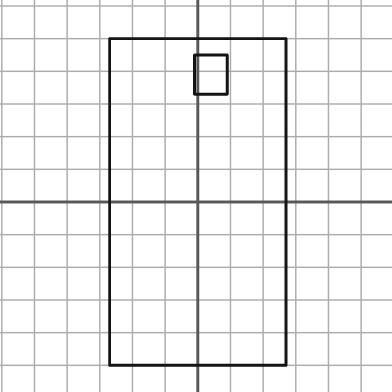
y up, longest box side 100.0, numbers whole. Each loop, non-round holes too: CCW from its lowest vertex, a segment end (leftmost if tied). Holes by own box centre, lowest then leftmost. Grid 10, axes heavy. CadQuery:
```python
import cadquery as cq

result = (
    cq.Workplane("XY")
    .moveTo(-27.0, -50.0)
    .lineTo(27.0, -50.0)
    .lineTo(27.0, 50.0)
    .lineTo(-27.0, 50.0)
    .close()
    .moveTo(-1.0, 33.0)
    .lineTo(9.0, 33.0)
    .lineTo(9.0, 45.0)
    .lineTo(-1.0, 45.0)
    .close()
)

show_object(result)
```